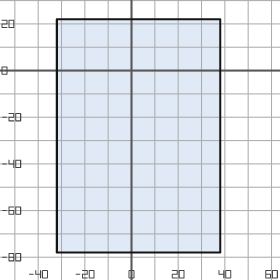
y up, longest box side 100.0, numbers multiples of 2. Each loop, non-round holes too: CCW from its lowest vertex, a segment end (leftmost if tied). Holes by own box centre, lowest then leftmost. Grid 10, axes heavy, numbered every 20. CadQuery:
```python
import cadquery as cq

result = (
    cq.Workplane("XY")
    .moveTo(-32.0, -78.0)
    .lineTo(38.0, -78.0)
    .lineTo(38.0, 22.0)
    .lineTo(-32.0, 22.0)
    .close()
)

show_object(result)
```